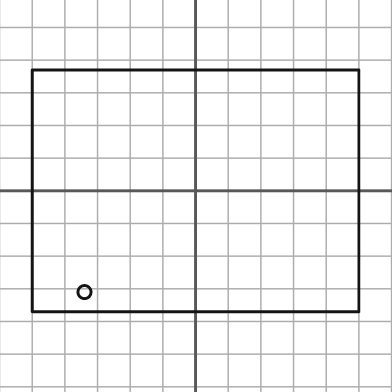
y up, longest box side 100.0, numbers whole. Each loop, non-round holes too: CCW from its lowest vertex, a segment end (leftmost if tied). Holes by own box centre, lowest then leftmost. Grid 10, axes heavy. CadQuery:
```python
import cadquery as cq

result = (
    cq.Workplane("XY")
    .moveTo(-50.0, -37.0)
    .lineTo(50.0, -37.0)
    .lineTo(50.0, 37.0)
    .lineTo(-50.0, 37.0)
    .close()
    .moveTo(-34.0, -31.0)
    .circle(2.0)
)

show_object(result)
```